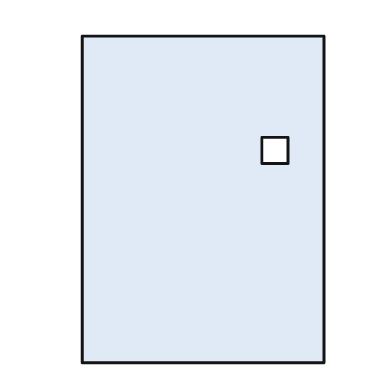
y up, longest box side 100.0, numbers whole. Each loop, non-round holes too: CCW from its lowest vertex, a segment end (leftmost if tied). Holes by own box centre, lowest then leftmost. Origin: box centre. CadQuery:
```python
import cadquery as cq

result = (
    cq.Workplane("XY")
    .moveTo(-37.0, -50.0)
    .lineTo(37.0, -50.0)
    .lineTo(37.0, 50.0)
    .lineTo(-37.0, 50.0)
    .close()
    .moveTo(18.0, 11.0)
    .lineTo(26.0, 11.0)
    .lineTo(26.0, 19.0)
    .lineTo(18.0, 19.0)
    .close()
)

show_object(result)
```